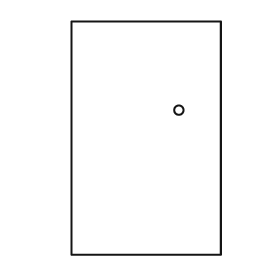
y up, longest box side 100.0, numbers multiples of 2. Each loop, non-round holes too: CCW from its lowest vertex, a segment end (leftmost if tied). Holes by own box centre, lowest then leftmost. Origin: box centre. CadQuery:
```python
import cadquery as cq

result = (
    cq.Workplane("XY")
    .moveTo(-32.0, -50.0)
    .lineTo(32.0, -50.0)
    .lineTo(32.0, 50.0)
    .lineTo(-32.0, 50.0)
    .close()
    .moveTo(14.0, 12.0)
    .circle(2.0)
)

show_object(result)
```